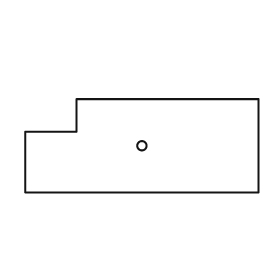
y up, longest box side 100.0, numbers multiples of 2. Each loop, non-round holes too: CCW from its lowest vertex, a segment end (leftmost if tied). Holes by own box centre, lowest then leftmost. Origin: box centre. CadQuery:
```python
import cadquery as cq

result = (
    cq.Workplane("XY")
    .moveTo(-50.0, -20.0)
    .lineTo(50.0, -20.0)
    .lineTo(50.0, 20.0)
    .lineTo(-28.0, 20.0)
    .lineTo(-28.0, 6.0)
    .lineTo(-50.0, 6.0)
    .close()
    .moveTo(0.0, 0.0)
    .circle(2.0)
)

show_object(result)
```